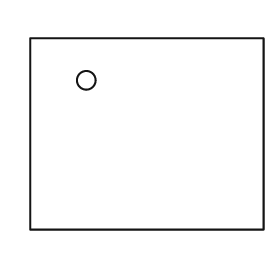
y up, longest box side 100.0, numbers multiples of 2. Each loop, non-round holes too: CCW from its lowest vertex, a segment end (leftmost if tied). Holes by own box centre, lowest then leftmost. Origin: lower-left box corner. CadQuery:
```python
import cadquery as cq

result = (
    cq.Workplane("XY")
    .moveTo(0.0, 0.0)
    .lineTo(100.0, 0.0)
    .lineTo(100.0, 82.0)
    .lineTo(0.0, 82.0)
    .close()
    .moveTo(24.0, 64.0)
    .circle(4.0)
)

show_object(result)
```